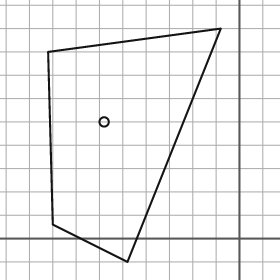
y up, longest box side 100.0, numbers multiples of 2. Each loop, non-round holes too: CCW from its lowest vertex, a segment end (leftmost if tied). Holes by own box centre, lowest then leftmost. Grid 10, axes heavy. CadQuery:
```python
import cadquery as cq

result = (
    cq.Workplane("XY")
    .moveTo(-48.0, -10.0)
    .lineTo(-8.0, 90.0)
    .lineTo(-82.0, 80.0)
    .lineTo(-80.0, 6.0)
    .close()
    .moveTo(-58.0, 50.0)
    .circle(2.0)
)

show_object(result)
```